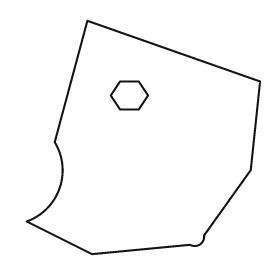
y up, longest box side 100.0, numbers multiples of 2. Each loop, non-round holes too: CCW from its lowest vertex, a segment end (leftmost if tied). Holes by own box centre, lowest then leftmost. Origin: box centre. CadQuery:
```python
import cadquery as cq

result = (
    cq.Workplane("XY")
    .moveTo(-22.0, -50.0)
    .lineTo(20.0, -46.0)
    .threePointArc((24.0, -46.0), (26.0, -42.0))
    .lineTo(46.0, -14.0)
    .lineTo(50.0, 24.0)
    .lineTo(-24.0, 50.0)
    .lineTo(-38.0, -2.0)
    .threePointArc((-36.0, -22.0), (-50.0, -36.0))
    .close()
    .moveTo(-10.0, 12.0)
    .lineTo(-2.0, 12.0)
    .lineTo(2.0, 18.0)
    .lineTo(-2.0, 24.0)
    .lineTo(-10.0, 24.0)
    .lineTo(-14.0, 18.0)
    .close()
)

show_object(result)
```